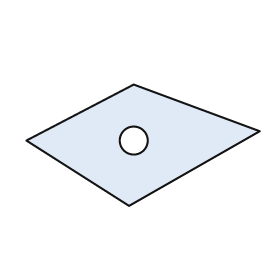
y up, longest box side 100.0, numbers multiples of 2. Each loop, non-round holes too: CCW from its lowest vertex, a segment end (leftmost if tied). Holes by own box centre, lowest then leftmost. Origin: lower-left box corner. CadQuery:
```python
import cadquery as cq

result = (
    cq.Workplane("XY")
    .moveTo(44.0, 0.0)
    .lineTo(100.0, 32.0)
    .lineTo(46.0, 52.0)
    .lineTo(0.0, 28.0)
    .close()
    .moveTo(46.0, 28.0)
    .circle(6.0)
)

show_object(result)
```